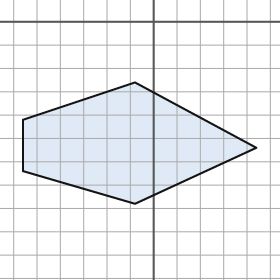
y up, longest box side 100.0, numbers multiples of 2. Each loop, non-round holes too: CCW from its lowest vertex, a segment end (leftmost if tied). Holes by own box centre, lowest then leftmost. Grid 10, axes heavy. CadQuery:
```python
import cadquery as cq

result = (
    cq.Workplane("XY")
    .moveTo(-8.0, -78.0)
    .lineTo(44.0, -54.0)
    .lineTo(-8.0, -26.0)
    .lineTo(-56.0, -42.0)
    .lineTo(-56.0, -64.0)
    .close()
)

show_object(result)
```